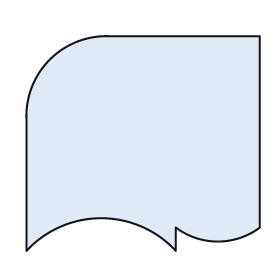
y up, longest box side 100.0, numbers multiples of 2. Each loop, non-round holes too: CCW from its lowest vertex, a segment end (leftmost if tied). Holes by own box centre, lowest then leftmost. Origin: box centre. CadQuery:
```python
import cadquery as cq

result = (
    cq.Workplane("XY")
    .moveTo(-50.0, -46.0)
    .threePointArc((-18.0, -32.0), (14.0, -46.0))
    .lineTo(14.0, -36.0)
    .threePointArc((32.0, -42.0), (50.0, -36.0))
    .lineTo(50.0, 46.0)
    .lineTo(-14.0, 46.0)
    .threePointArc((-40.0, 36.0), (-50.0, 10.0))
    .close()
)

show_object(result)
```